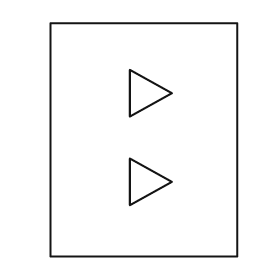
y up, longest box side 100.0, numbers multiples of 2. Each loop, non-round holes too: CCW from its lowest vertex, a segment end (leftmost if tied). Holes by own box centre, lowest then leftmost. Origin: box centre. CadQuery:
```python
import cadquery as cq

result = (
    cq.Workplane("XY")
    .moveTo(-40.0, -50.0)
    .lineTo(40.0, -50.0)
    .lineTo(40.0, 50.0)
    .lineTo(-40.0, 50.0)
    .close()
    .moveTo(-6.0, -28.0)
    .lineTo(12.0, -18.0)
    .lineTo(-6.0, -8.0)
    .close()
    .moveTo(-6.0, 10.0)
    .lineTo(12.0, 20.0)
    .lineTo(-6.0, 30.0)
    .close()
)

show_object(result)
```